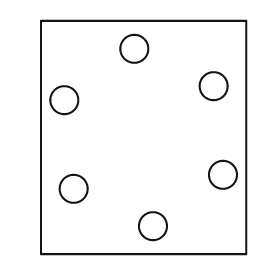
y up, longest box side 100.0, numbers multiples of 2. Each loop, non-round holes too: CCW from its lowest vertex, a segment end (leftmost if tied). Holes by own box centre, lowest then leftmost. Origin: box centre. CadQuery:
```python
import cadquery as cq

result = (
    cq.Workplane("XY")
    .moveTo(-44.0, -50.0)
    .lineTo(44.0, -50.0)
    .lineTo(44.0, 50.0)
    .lineTo(-44.0, 50.0)
    .close()
    .moveTo(4.0, -38.0)
    .circle(6.0)
    .moveTo(-30.0, -22.0)
    .circle(6.0)
    .moveTo(34.0, -16.0)
    .circle(6.0)
    .moveTo(-34.0, 16.0)
    .circle(6.0)
    .moveTo(30.0, 22.0)
    .circle(6.0)
    .moveTo(-4.0, 38.0)
    .circle(6.0)
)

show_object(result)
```